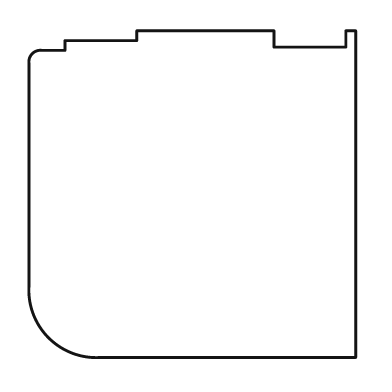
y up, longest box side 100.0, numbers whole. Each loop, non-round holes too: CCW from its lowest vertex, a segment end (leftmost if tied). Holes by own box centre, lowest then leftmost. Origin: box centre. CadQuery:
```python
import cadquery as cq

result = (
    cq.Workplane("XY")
    .moveTo(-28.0, -50.0)
    .lineTo(50.0, -50.0)
    .lineTo(50.0, 50.0)
    .lineTo(47.0, 50.0)
    .lineTo(47.0, 45.0)
    .lineTo(25.0, 45.0)
    .lineTo(25.0, 50.0)
    .lineTo(-17.0, 50.0)
    .lineTo(-17.0, 47.0)
    .lineTo(-39.0, 47.0)
    .lineTo(-39.0, 44.0)
    .lineTo(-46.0, 44.0)
    .threePointArc((-49.0, 43.0), (-50.0, 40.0))
    .lineTo(-50.0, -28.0)
    .threePointArc((-44.0, -44.0), (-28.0, -50.0))
    .close()
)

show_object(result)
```